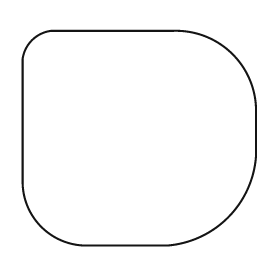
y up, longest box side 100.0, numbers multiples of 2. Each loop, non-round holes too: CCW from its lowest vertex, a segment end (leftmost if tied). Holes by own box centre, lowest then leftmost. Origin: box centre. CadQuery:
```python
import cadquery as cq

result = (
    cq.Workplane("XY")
    .moveTo(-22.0, -46.0)
    .lineTo(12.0, -46.0)
    .threePointArc((38.0, -34.0), (50.0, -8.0))
    .lineTo(50.0, 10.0)
    .threePointArc((40.0, 36.0), (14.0, 46.0))
    .lineTo(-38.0, 46.0)
    .threePointArc((-46.0, 42.0), (-50.0, 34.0))
    .lineTo(-50.0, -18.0)
    .threePointArc((-42.0, -38.0), (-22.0, -46.0))
    .close()
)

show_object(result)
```